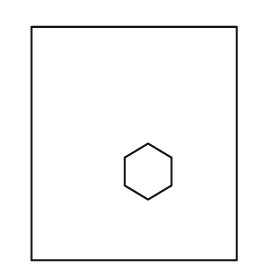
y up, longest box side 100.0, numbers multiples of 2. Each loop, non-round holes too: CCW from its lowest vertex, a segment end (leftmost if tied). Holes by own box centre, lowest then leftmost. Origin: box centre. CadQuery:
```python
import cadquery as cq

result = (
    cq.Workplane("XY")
    .moveTo(-44.0, -50.0)
    .lineTo(44.0, -50.0)
    .lineTo(44.0, 50.0)
    .lineTo(-44.0, 50.0)
    .close()
    .moveTo(6.0, -24.0)
    .lineTo(16.0, -18.0)
    .lineTo(16.0, -6.0)
    .lineTo(6.0, 0.0)
    .lineTo(-4.0, -6.0)
    .lineTo(-4.0, -18.0)
    .close()
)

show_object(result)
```